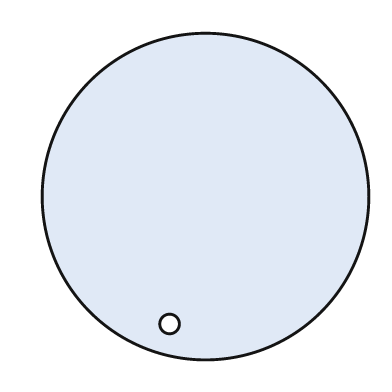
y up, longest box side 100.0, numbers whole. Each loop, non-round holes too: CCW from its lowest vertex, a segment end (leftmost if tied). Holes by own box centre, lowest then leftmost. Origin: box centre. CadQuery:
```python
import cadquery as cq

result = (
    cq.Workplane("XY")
    .moveTo(0.0, 0.0)
    .circle(50.0)
    .moveTo(-11.0, -39.0)
    .circle(3.0)
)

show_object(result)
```